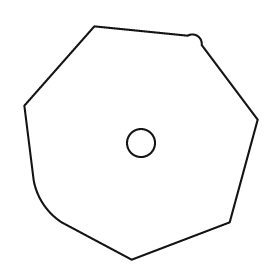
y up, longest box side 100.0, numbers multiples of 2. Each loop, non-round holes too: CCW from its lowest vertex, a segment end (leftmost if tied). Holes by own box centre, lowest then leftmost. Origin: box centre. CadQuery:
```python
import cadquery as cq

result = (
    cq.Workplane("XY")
    .moveTo(-4.0, -50.0)
    .lineTo(38.0, -34.0)
    .lineTo(50.0, 10.0)
    .lineTo(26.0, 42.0)
    .threePointArc((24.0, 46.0), (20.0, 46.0))
    .lineTo(-20.0, 50.0)
    .lineTo(-50.0, 16.0)
    .lineTo(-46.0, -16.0)
    .threePointArc((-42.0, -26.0), (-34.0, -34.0))
    .close()
    .moveTo(0.0, 0.0)
    .circle(6.0)
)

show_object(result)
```